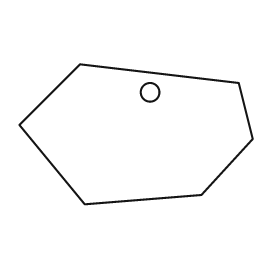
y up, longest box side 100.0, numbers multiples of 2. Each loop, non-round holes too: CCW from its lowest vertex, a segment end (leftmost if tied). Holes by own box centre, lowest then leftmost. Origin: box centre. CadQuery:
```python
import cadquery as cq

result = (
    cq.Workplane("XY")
    .moveTo(-22.0, -30.0)
    .lineTo(28.0, -26.0)
    .lineTo(50.0, -2.0)
    .lineTo(44.0, 22.0)
    .lineTo(-24.0, 30.0)
    .lineTo(-50.0, 4.0)
    .close()
    .moveTo(6.0, 18.0)
    .circle(4.0)
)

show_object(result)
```